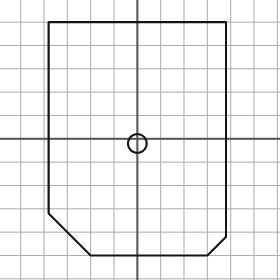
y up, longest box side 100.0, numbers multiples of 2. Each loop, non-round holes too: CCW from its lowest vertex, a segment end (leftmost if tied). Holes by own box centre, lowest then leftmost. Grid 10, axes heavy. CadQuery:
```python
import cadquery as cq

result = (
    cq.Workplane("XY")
    .moveTo(-20.0, -50.0)
    .lineTo(30.0, -50.0)
    .lineTo(38.0, -42.0)
    .lineTo(38.0, 50.0)
    .lineTo(-38.0, 50.0)
    .lineTo(-38.0, -32.0)
    .close()
    .moveTo(0.0, -2.0)
    .circle(4.0)
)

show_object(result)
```